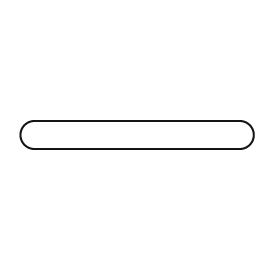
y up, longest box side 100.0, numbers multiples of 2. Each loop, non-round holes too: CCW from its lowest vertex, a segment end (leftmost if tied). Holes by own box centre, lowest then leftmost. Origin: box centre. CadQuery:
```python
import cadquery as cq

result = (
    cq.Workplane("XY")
    .moveTo(-44.0, -6.0)
    .lineTo(44.0, -6.0)
    .threePointArc((50.0, 0.0), (44.0, 6.0))
    .lineTo(-44.0, 6.0)
    .threePointArc((-50.0, 0.0), (-44.0, -6.0))
    .close()
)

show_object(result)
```